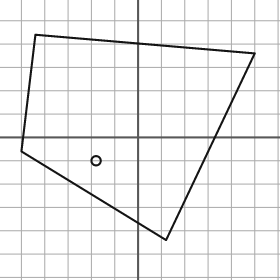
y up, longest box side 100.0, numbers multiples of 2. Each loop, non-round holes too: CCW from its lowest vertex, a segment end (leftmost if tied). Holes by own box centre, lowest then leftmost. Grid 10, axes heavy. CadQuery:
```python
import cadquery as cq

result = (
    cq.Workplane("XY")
    .moveTo(12.0, -44.0)
    .lineTo(50.0, 36.0)
    .lineTo(-44.0, 44.0)
    .lineTo(-50.0, -6.0)
    .close()
    .moveTo(-18.0, -10.0)
    .circle(2.0)
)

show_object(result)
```